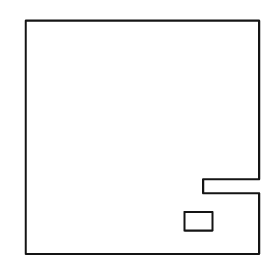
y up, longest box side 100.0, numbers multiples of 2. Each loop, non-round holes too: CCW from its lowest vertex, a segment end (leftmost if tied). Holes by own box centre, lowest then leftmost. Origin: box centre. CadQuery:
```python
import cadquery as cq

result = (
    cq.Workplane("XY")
    .moveTo(-50.0, -50.0)
    .lineTo(50.0, -50.0)
    .lineTo(50.0, -24.0)
    .lineTo(26.0, -24.0)
    .lineTo(26.0, -18.0)
    .lineTo(50.0, -18.0)
    .lineTo(50.0, 50.0)
    .lineTo(-50.0, 50.0)
    .close()
    .moveTo(18.0, -40.0)
    .lineTo(30.0, -40.0)
    .lineTo(30.0, -32.0)
    .lineTo(18.0, -32.0)
    .close()
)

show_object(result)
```